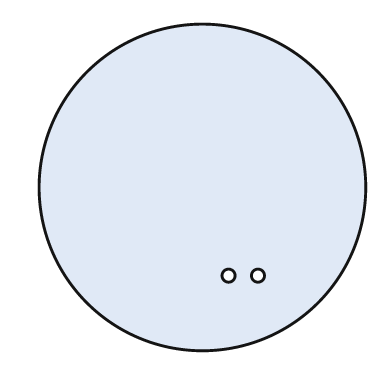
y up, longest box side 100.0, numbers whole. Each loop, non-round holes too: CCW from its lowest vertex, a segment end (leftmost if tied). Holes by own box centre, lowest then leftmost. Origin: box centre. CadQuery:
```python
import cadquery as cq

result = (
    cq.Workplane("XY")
    .moveTo(0.0, 0.0)
    .circle(50.0)
    .moveTo(8.0, -27.0)
    .circle(2.0)
    .moveTo(17.0, -27.0)
    .circle(2.0)
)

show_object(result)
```